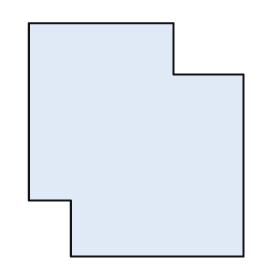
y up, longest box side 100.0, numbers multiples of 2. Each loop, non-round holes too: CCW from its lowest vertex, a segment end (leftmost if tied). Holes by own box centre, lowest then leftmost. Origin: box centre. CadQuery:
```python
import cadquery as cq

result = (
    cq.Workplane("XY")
    .moveTo(-28.0, -50.0)
    .lineTo(46.0, -50.0)
    .lineTo(46.0, 28.0)
    .lineTo(16.0, 28.0)
    .lineTo(16.0, 50.0)
    .lineTo(-46.0, 50.0)
    .lineTo(-46.0, -26.0)
    .lineTo(-28.0, -26.0)
    .close()
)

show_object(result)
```